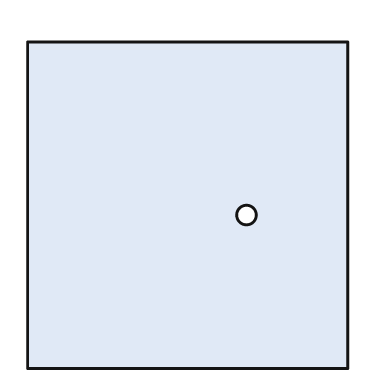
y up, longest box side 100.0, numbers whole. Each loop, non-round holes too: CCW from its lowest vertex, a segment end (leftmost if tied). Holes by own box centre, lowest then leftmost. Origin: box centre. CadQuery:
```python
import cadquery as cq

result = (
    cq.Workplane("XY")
    .moveTo(-49.0, -50.0)
    .lineTo(49.0, -50.0)
    .lineTo(49.0, 50.0)
    .lineTo(-49.0, 50.0)
    .close()
    .moveTo(18.0, -3.0)
    .circle(3.0)
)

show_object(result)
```